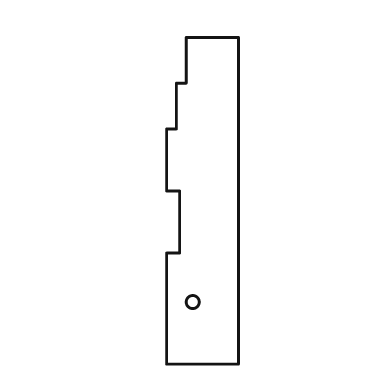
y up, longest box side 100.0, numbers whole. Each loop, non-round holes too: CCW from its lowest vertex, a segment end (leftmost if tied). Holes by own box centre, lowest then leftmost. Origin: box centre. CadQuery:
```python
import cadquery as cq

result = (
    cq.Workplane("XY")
    .moveTo(-11.0, -50.0)
    .lineTo(11.0, -50.0)
    .lineTo(11.0, 50.0)
    .lineTo(-5.0, 50.0)
    .lineTo(-5.0, 36.0)
    .lineTo(-8.0, 36.0)
    .lineTo(-8.0, 22.0)
    .lineTo(-11.0, 22.0)
    .lineTo(-11.0, 3.0)
    .lineTo(-7.0, 3.0)
    .lineTo(-7.0, -16.0)
    .lineTo(-11.0, -16.0)
    .close()
    .moveTo(-3.0, -31.0)
    .circle(2.0)
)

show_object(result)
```